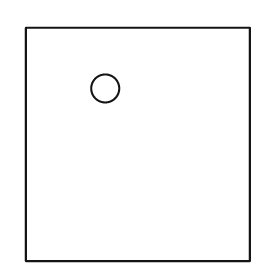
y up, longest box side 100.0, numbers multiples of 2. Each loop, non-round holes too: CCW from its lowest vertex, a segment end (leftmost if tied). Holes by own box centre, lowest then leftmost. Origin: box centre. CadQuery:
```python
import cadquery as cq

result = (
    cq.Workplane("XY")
    .moveTo(-48.0, -50.0)
    .lineTo(48.0, -50.0)
    .lineTo(48.0, 50.0)
    .lineTo(-48.0, 50.0)
    .close()
    .moveTo(-14.0, 24.0)
    .circle(6.0)
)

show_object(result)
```